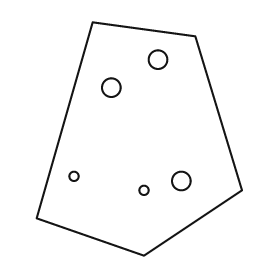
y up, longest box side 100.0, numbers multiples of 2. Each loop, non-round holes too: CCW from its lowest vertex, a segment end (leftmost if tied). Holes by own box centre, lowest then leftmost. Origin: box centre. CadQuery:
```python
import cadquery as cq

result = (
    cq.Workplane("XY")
    .moveTo(2.0, -50.0)
    .lineTo(44.0, -22.0)
    .lineTo(24.0, 44.0)
    .lineTo(-20.0, 50.0)
    .lineTo(-44.0, -34.0)
    .close()
    .moveTo(2.0, -22.0)
    .circle(2.0)
    .moveTo(18.0, -18.0)
    .circle(4.0)
    .moveTo(-28.0, -16.0)
    .circle(2.0)
    .moveTo(-12.0, 22.0)
    .circle(4.0)
    .moveTo(8.0, 34.0)
    .circle(4.0)
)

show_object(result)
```